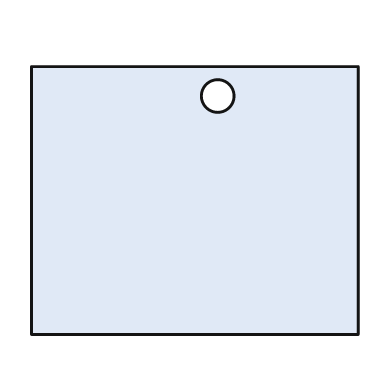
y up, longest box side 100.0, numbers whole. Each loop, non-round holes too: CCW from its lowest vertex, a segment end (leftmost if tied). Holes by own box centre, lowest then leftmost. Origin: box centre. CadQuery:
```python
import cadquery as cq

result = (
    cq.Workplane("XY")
    .moveTo(-50.0, -41.0)
    .lineTo(50.0, -41.0)
    .lineTo(50.0, 41.0)
    .lineTo(-50.0, 41.0)
    .close()
    .moveTo(7.0, 32.0)
    .circle(5.0)
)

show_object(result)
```